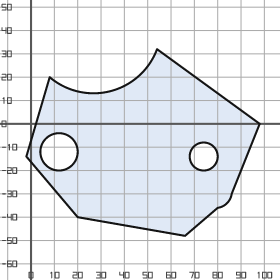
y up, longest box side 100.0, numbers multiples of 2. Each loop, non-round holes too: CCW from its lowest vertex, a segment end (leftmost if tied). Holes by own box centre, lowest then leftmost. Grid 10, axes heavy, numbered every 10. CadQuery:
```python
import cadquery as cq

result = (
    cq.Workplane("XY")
    .moveTo(66.0, -48.0)
    .lineTo(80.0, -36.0)
    .threePointArc((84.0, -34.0), (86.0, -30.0))
    .lineTo(98.0, 0.0)
    .lineTo(54.0, 32.0)
    .threePointArc((34.0, 14.0), (8.0, 20.0))
    .lineTo(-2.0, -14.0)
    .lineTo(20.0, -40.0)
    .close()
    .moveTo(74.0, -14.0)
    .circle(6.0)
    .moveTo(12.0, -12.0)
    .circle(8.0)
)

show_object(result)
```